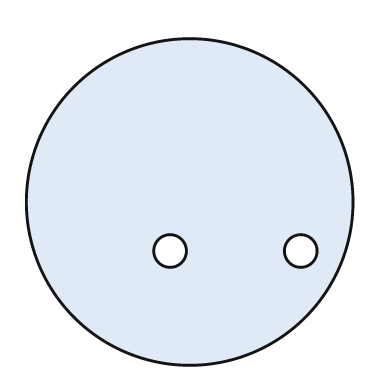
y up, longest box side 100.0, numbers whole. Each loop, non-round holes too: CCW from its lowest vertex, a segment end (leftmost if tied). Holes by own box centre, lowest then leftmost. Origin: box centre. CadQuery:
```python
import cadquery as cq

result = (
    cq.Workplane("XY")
    .moveTo(0.0, 0.0)
    .circle(50.0)
    .moveTo(-6.0, -15.0)
    .circle(5.0)
    .moveTo(34.0, -15.0)
    .circle(5.0)
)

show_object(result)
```